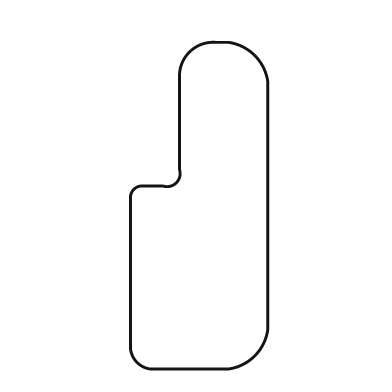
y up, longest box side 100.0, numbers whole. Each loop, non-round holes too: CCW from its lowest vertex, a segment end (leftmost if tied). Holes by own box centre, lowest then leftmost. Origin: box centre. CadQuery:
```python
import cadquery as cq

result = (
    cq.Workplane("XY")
    .moveTo(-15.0, -50.0)
    .lineTo(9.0, -50.0)
    .threePointArc((17.0, -46.0), (21.0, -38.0))
    .lineTo(21.0, 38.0)
    .threePointArc((17.0, 46.0), (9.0, 50.0))
    .lineTo(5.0, 50.0)
    .threePointArc((-3.0, 47.0), (-6.0, 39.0))
    .lineTo(-6.0, 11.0)
    .threePointArc((-7.0, 7.0), (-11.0, 6.0))
    .lineTo(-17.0, 6.0)
    .threePointArc((-20.0, 5.0), (-21.0, 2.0))
    .lineTo(-21.0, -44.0)
    .threePointArc((-19.0, -48.0), (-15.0, -50.0))
    .close()
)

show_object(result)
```